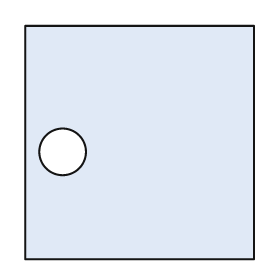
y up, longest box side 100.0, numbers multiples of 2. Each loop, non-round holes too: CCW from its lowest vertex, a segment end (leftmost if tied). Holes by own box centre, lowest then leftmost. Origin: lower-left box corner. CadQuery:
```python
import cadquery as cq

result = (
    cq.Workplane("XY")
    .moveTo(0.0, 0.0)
    .lineTo(98.0, 0.0)
    .lineTo(98.0, 100.0)
    .lineTo(0.0, 100.0)
    .close()
    .moveTo(16.0, 46.0)
    .circle(10.0)
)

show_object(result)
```